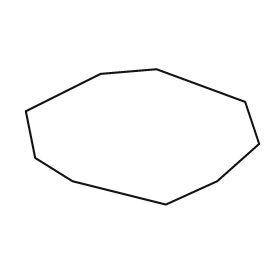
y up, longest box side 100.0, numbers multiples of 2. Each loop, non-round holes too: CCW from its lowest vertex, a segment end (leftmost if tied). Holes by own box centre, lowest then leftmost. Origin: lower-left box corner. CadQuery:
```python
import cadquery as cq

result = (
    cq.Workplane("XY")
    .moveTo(60.0, 0.0)
    .lineTo(82.0, 10.0)
    .lineTo(100.0, 26.0)
    .lineTo(94.0, 44.0)
    .lineTo(56.0, 58.0)
    .lineTo(32.0, 56.0)
    .lineTo(0.0, 40.0)
    .lineTo(4.0, 20.0)
    .lineTo(20.0, 10.0)
    .close()
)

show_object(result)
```